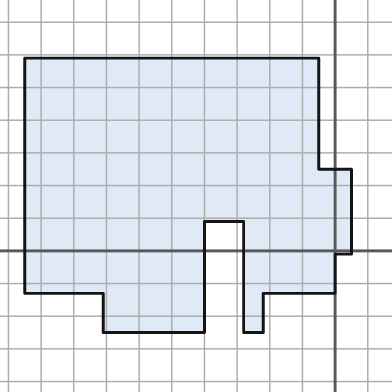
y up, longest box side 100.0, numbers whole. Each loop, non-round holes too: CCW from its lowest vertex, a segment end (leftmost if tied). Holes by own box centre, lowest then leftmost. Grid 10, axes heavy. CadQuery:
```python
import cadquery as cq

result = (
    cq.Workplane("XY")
    .moveTo(-71.0, -25.0)
    .lineTo(-40.0, -25.0)
    .lineTo(-40.0, 9.0)
    .lineTo(-28.0, 9.0)
    .lineTo(-28.0, -25.0)
    .lineTo(-22.0, -25.0)
    .lineTo(-22.0, -13.0)
    .lineTo(0.0, -13.0)
    .lineTo(0.0, -1.0)
    .lineTo(5.0, -1.0)
    .lineTo(5.0, 25.0)
    .lineTo(-5.0, 25.0)
    .lineTo(-5.0, 59.0)
    .lineTo(-95.0, 59.0)
    .lineTo(-95.0, -13.0)
    .lineTo(-71.0, -13.0)
    .close()
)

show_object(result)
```